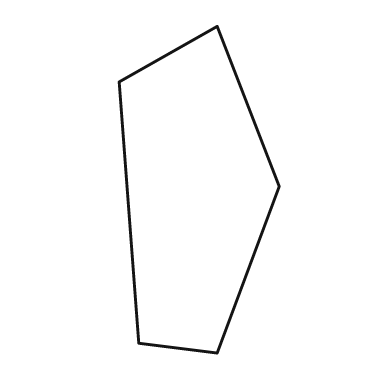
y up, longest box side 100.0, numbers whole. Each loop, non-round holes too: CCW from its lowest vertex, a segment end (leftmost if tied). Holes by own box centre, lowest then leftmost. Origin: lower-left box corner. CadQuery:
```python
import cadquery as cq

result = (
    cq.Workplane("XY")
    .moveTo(30.0, 0.0)
    .lineTo(49.0, 51.0)
    .lineTo(30.0, 100.0)
    .lineTo(0.0, 83.0)
    .lineTo(6.0, 3.0)
    .close()
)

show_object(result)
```